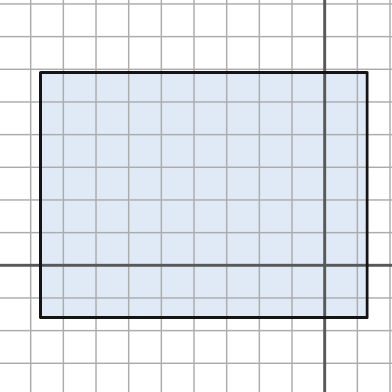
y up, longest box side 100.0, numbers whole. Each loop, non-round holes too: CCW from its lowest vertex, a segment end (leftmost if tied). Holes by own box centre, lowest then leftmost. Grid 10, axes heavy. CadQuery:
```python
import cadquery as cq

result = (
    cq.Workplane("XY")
    .moveTo(-87.0, -16.0)
    .lineTo(13.0, -16.0)
    .lineTo(13.0, 59.0)
    .lineTo(-87.0, 59.0)
    .close()
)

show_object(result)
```